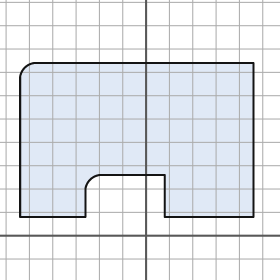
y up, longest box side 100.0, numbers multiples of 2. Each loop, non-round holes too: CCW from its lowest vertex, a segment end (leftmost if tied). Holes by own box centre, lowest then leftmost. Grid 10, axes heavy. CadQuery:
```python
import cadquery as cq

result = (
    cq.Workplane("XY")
    .moveTo(-54.0, 8.0)
    .lineTo(-26.0, 8.0)
    .lineTo(-26.0, 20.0)
    .threePointArc((-24.0, 24.0), (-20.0, 26.0))
    .lineTo(8.0, 26.0)
    .lineTo(8.0, 8.0)
    .lineTo(46.0, 8.0)
    .lineTo(46.0, 74.0)
    .lineTo(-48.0, 74.0)
    .threePointArc((-52.0, 72.0), (-54.0, 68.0))
    .close()
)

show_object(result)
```